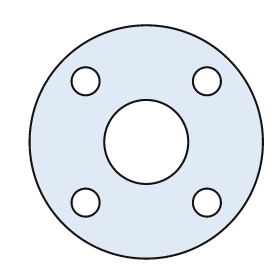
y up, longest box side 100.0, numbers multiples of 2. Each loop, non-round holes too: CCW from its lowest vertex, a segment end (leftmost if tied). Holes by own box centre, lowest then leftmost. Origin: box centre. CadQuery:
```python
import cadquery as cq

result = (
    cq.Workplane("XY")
    .moveTo(0.0, 0.0)
    .circle(50.0)
    .moveTo(-26.0, -26.0)
    .circle(6.0)
    .moveTo(26.0, -26.0)
    .circle(6.0)
    .moveTo(0.0, 0.0)
    .circle(18.0)
    .moveTo(-26.0, 26.0)
    .circle(6.0)
    .moveTo(26.0, 26.0)
    .circle(6.0)
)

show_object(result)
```